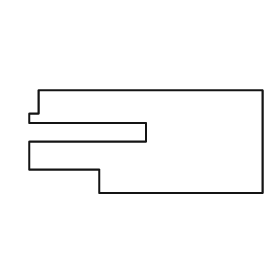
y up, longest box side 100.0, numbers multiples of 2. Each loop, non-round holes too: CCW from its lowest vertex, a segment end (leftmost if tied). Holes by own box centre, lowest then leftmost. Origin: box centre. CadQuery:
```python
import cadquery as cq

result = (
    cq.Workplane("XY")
    .moveTo(-20.0, -22.0)
    .lineTo(50.0, -22.0)
    .lineTo(50.0, 22.0)
    .lineTo(-46.0, 22.0)
    .lineTo(-46.0, 12.0)
    .lineTo(-50.0, 12.0)
    .lineTo(-50.0, 8.0)
    .lineTo(0.0, 8.0)
    .lineTo(0.0, 0.0)
    .lineTo(-50.0, 0.0)
    .lineTo(-50.0, -12.0)
    .lineTo(-20.0, -12.0)
    .close()
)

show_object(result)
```